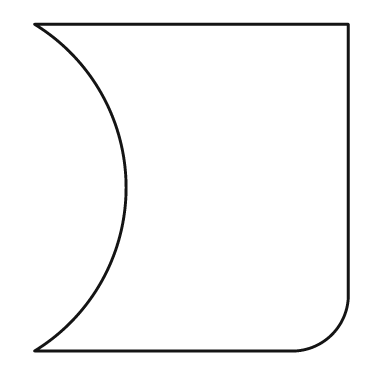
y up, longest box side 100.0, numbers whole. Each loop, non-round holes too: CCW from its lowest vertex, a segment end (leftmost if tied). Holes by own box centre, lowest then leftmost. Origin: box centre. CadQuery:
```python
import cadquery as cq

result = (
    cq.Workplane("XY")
    .moveTo(-48.0, -50.0)
    .lineTo(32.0, -50.0)
    .threePointArc((43.0, -45.0), (48.0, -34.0))
    .lineTo(48.0, 50.0)
    .lineTo(-48.0, 50.0)
    .threePointArc((-20.0, 0.0), (-48.0, -50.0))
    .close()
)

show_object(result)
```